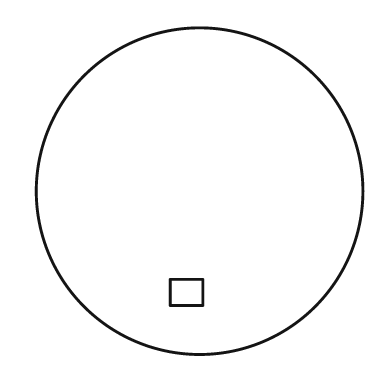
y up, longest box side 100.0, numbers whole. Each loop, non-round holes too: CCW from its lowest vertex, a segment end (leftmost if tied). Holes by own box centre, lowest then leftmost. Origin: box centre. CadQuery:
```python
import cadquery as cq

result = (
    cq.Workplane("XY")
    .moveTo(0.0, 0.0)
    .circle(50.0)
    .moveTo(-9.0, -35.0)
    .lineTo(1.0, -35.0)
    .lineTo(1.0, -27.0)
    .lineTo(-9.0, -27.0)
    .close()
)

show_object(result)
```